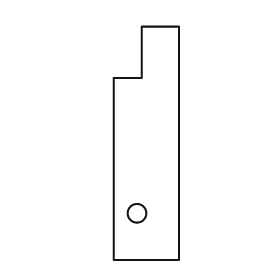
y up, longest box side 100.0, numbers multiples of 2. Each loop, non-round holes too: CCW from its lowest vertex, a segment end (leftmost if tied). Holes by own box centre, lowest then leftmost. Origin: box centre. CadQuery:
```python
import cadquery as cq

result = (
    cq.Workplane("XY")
    .moveTo(-14.0, -50.0)
    .lineTo(14.0, -50.0)
    .lineTo(14.0, 50.0)
    .lineTo(-2.0, 50.0)
    .lineTo(-2.0, 28.0)
    .lineTo(-14.0, 28.0)
    .close()
    .moveTo(-4.0, -30.0)
    .circle(4.0)
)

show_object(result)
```